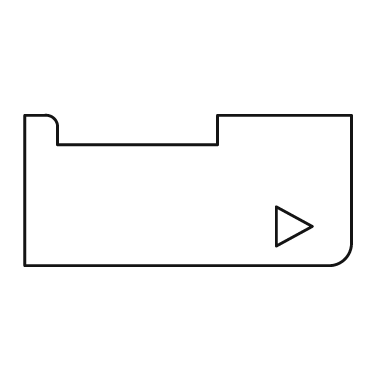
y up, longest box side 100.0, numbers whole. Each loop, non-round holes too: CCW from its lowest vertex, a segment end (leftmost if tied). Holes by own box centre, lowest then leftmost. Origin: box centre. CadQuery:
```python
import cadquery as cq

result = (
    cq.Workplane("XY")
    .moveTo(-50.0, -23.0)
    .lineTo(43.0, -23.0)
    .threePointArc((48.0, -21.0), (50.0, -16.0))
    .lineTo(50.0, 23.0)
    .lineTo(9.0, 23.0)
    .lineTo(9.0, 14.0)
    .lineTo(-40.0, 14.0)
    .lineTo(-40.0, 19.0)
    .threePointArc((-41.0, 22.0), (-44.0, 23.0))
    .lineTo(-50.0, 23.0)
    .close()
    .moveTo(27.0, -17.0)
    .lineTo(38.0, -11.0)
    .lineTo(27.0, -5.0)
    .close()
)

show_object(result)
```